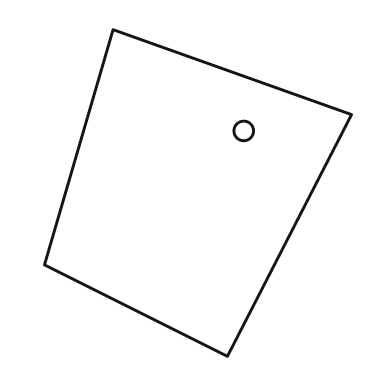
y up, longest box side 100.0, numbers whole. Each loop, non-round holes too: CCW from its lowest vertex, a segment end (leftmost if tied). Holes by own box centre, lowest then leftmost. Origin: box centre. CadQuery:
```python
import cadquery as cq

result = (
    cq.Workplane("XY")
    .moveTo(9.0, -50.0)
    .lineTo(47.0, 24.0)
    .lineTo(-26.0, 50.0)
    .lineTo(-47.0, -22.0)
    .close()
    .moveTo(14.0, 19.0)
    .circle(3.0)
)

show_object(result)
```